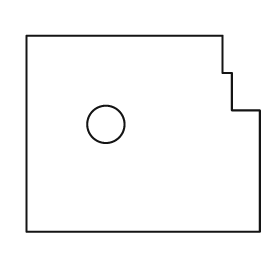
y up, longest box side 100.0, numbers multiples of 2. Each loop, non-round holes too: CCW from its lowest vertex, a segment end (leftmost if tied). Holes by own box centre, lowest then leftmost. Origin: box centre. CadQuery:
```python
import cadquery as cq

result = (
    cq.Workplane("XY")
    .moveTo(-50.0, -42.0)
    .lineTo(50.0, -42.0)
    .lineTo(50.0, 10.0)
    .lineTo(38.0, 10.0)
    .lineTo(38.0, 26.0)
    .lineTo(34.0, 26.0)
    .lineTo(34.0, 42.0)
    .lineTo(-50.0, 42.0)
    .close()
    .moveTo(-16.0, 4.0)
    .circle(8.0)
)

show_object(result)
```